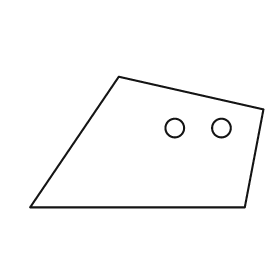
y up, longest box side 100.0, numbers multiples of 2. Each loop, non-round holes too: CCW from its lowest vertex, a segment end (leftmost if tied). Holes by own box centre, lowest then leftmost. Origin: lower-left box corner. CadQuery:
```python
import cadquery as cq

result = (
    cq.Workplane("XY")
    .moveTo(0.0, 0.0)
    .lineTo(92.0, 0.0)
    .lineTo(100.0, 42.0)
    .lineTo(38.0, 56.0)
    .close()
    .moveTo(62.0, 34.0)
    .circle(4.0)
    .moveTo(82.0, 34.0)
    .circle(4.0)
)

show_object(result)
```